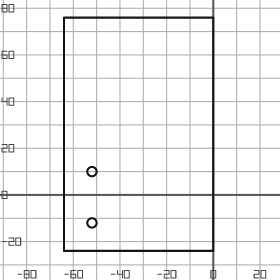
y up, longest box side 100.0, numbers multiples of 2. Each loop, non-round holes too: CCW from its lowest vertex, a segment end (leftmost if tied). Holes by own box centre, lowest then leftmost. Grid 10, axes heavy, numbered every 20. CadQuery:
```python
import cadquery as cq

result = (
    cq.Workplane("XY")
    .moveTo(-64.0, -24.0)
    .lineTo(0.0, -24.0)
    .lineTo(0.0, 76.0)
    .lineTo(-64.0, 76.0)
    .close()
    .moveTo(-52.0, -12.0)
    .circle(2.0)
    .moveTo(-52.0, 10.0)
    .circle(2.0)
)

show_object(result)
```